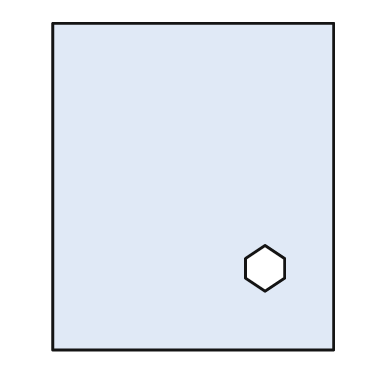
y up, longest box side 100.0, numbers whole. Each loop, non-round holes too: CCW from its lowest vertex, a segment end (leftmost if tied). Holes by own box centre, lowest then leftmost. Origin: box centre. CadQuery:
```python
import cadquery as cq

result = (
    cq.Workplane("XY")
    .moveTo(-43.0, -50.0)
    .lineTo(43.0, -50.0)
    .lineTo(43.0, 50.0)
    .lineTo(-43.0, 50.0)
    .close()
    .moveTo(22.0, -32.0)
    .lineTo(28.0, -28.0)
    .lineTo(28.0, -22.0)
    .lineTo(22.0, -18.0)
    .lineTo(16.0, -22.0)
    .lineTo(16.0, -28.0)
    .close()
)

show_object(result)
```